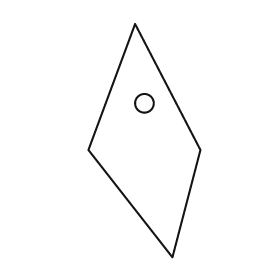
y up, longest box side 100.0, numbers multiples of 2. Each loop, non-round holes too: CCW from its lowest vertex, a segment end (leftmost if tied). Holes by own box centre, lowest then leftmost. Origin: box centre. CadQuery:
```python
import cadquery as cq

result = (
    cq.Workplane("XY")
    .moveTo(12.0, -50.0)
    .lineTo(24.0, -4.0)
    .lineTo(-4.0, 50.0)
    .lineTo(-24.0, -4.0)
    .close()
    .moveTo(0.0, 16.0)
    .circle(4.0)
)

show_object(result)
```